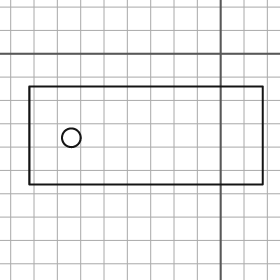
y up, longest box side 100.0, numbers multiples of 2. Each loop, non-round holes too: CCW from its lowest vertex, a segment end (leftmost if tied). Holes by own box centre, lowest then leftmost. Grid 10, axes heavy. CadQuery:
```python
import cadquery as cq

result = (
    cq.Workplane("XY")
    .moveTo(-82.0, -56.0)
    .lineTo(18.0, -56.0)
    .lineTo(18.0, -14.0)
    .lineTo(-82.0, -14.0)
    .close()
    .moveTo(-64.0, -36.0)
    .circle(4.0)
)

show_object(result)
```